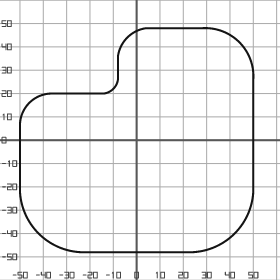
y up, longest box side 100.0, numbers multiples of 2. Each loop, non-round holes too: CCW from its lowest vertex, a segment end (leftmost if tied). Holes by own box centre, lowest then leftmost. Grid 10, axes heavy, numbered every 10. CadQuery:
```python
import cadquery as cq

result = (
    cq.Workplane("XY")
    .moveTo(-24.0, -48.0)
    .lineTo(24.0, -48.0)
    .threePointArc((42.0, -40.0), (50.0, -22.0))
    .lineTo(50.0, 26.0)
    .threePointArc((44.0, 42.0), (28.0, 48.0))
    .lineTo(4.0, 48.0)
    .threePointArc((-4.0, 44.0), (-8.0, 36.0))
    .lineTo(-8.0, 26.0)
    .threePointArc((-10.0, 22.0), (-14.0, 20.0))
    .lineTo(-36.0, 20.0)
    .threePointArc((-46.0, 16.0), (-50.0, 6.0))
    .lineTo(-50.0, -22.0)
    .threePointArc((-42.0, -40.0), (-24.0, -48.0))
    .close()
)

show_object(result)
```